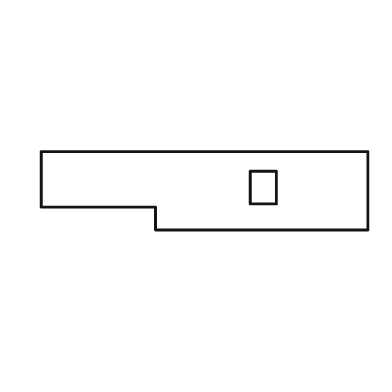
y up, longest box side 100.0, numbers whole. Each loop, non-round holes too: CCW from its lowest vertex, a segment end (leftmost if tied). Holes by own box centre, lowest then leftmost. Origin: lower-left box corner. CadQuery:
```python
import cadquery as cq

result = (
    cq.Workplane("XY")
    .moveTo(35.0, 0.0)
    .lineTo(100.0, 0.0)
    .lineTo(100.0, 24.0)
    .lineTo(0.0, 24.0)
    .lineTo(0.0, 7.0)
    .lineTo(35.0, 7.0)
    .close()
    .moveTo(64.0, 8.0)
    .lineTo(72.0, 8.0)
    .lineTo(72.0, 18.0)
    .lineTo(64.0, 18.0)
    .close()
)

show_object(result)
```